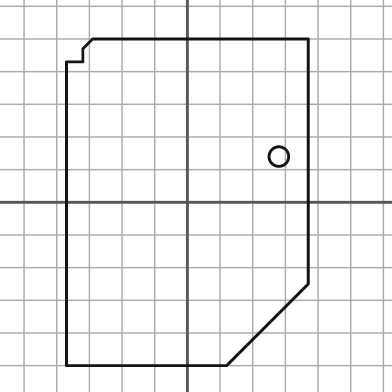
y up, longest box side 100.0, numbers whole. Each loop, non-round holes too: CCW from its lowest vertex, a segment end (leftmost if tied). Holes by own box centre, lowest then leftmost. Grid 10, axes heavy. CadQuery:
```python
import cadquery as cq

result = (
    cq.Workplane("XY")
    .moveTo(-37.0, -50.0)
    .lineTo(12.0, -50.0)
    .lineTo(37.0, -25.0)
    .lineTo(37.0, 50.0)
    .lineTo(-29.0, 50.0)
    .lineTo(-32.0, 47.0)
    .lineTo(-32.0, 43.0)
    .lineTo(-37.0, 43.0)
    .close()
    .moveTo(28.0, 14.0)
    .circle(3.0)
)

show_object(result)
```